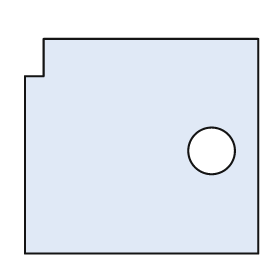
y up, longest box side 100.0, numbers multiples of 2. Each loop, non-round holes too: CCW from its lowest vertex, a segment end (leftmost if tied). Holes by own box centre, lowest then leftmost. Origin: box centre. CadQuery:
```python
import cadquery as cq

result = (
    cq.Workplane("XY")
    .moveTo(-50.0, -46.0)
    .lineTo(50.0, -46.0)
    .lineTo(50.0, 46.0)
    .lineTo(-42.0, 46.0)
    .lineTo(-42.0, 30.0)
    .lineTo(-50.0, 30.0)
    .close()
    .moveTo(30.0, -2.0)
    .circle(10.0)
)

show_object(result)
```